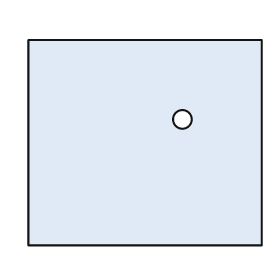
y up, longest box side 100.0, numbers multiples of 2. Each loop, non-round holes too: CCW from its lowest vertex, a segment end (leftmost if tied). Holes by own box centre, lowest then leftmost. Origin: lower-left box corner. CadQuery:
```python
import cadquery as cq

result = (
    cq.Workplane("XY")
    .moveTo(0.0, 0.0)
    .lineTo(100.0, 0.0)
    .lineTo(100.0, 88.0)
    .lineTo(0.0, 88.0)
    .close()
    .moveTo(66.0, 54.0)
    .circle(4.0)
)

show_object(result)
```